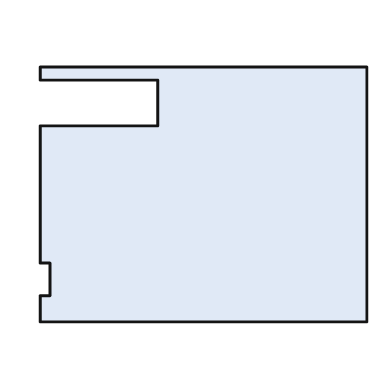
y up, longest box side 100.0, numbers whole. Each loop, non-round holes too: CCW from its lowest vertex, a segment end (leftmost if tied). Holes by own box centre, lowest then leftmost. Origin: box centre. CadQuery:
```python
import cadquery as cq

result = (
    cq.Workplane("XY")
    .moveTo(-50.0, -39.0)
    .lineTo(50.0, -39.0)
    .lineTo(50.0, 39.0)
    .lineTo(-50.0, 39.0)
    .lineTo(-50.0, 35.0)
    .lineTo(-14.0, 35.0)
    .lineTo(-14.0, 21.0)
    .lineTo(-50.0, 21.0)
    .lineTo(-50.0, -21.0)
    .lineTo(-47.0, -21.0)
    .lineTo(-47.0, -31.0)
    .lineTo(-50.0, -31.0)
    .close()
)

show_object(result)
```